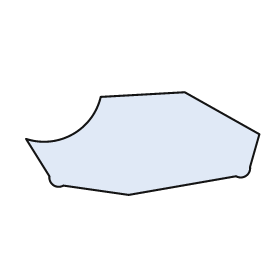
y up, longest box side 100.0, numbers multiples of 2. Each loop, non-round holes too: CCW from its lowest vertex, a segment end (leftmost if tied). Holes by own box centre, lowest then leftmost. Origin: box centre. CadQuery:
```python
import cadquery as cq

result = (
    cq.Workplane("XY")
    .moveTo(-6.0, -22.0)
    .lineTo(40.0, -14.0)
    .threePointArc((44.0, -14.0), (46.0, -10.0))
    .lineTo(50.0, 4.0)
    .lineTo(18.0, 22.0)
    .lineTo(-18.0, 20.0)
    .threePointArc((-30.0, 4.0), (-50.0, 2.0))
    .lineTo(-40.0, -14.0)
    .threePointArc((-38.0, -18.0), (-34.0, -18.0))
    .close()
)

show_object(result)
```